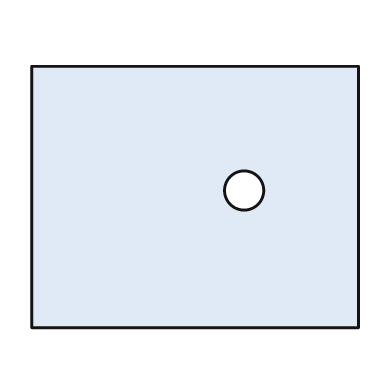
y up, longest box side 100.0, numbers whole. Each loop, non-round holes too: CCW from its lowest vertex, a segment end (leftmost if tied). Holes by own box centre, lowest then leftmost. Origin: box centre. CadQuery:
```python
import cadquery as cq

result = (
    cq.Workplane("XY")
    .moveTo(-50.0, -40.0)
    .lineTo(50.0, -40.0)
    .lineTo(50.0, 40.0)
    .lineTo(-50.0, 40.0)
    .close()
    .moveTo(15.0, 2.0)
    .circle(6.0)
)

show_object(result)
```